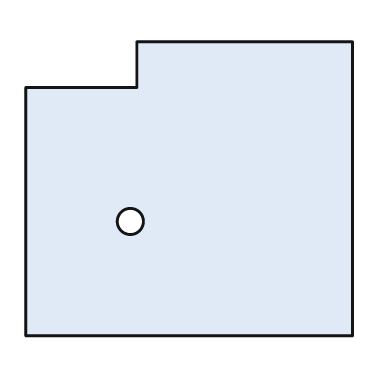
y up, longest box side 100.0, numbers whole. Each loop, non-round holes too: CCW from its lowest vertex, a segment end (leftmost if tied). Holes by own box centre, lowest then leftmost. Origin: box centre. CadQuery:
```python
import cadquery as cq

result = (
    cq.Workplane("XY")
    .moveTo(-50.0, -45.0)
    .lineTo(50.0, -45.0)
    .lineTo(50.0, 45.0)
    .lineTo(-16.0, 45.0)
    .lineTo(-16.0, 31.0)
    .lineTo(-50.0, 31.0)
    .close()
    .moveTo(-18.0, -10.0)
    .circle(4.0)
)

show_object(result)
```